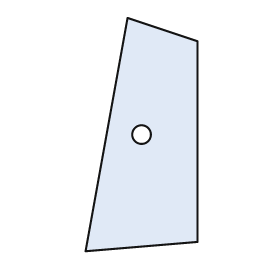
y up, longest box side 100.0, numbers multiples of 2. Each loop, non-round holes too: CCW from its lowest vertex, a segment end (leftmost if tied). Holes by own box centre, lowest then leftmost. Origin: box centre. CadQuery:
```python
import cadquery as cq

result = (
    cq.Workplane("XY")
    .moveTo(-24.0, -50.0)
    .lineTo(24.0, -46.0)
    .lineTo(24.0, 40.0)
    .lineTo(-6.0, 50.0)
    .close()
    .moveTo(0.0, 0.0)
    .circle(4.0)
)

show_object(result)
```